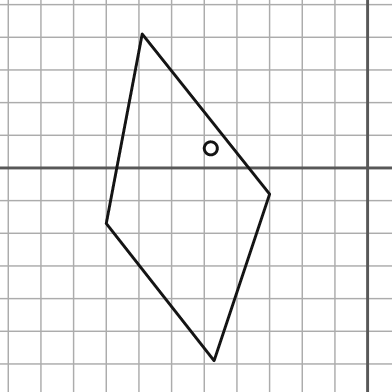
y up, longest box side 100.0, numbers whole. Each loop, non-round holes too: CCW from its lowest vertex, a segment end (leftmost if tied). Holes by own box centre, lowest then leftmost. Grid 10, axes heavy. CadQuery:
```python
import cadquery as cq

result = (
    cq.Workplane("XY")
    .moveTo(-47.0, -59.0)
    .lineTo(-30.0, -8.0)
    .lineTo(-69.0, 41.0)
    .lineTo(-80.0, -17.0)
    .close()
    .moveTo(-48.0, 6.0)
    .circle(2.0)
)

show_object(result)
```